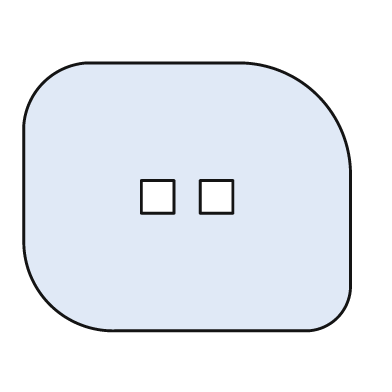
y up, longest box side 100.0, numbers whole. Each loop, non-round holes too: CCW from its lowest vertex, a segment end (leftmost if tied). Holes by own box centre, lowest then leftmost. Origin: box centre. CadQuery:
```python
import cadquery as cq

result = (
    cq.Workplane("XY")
    .moveTo(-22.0, -41.0)
    .lineTo(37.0, -41.0)
    .threePointArc((46.0, -37.0), (50.0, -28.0))
    .lineTo(50.0, 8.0)
    .threePointArc((40.0, 31.0), (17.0, 41.0))
    .lineTo(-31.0, 41.0)
    .threePointArc((-44.0, 35.0), (-50.0, 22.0))
    .lineTo(-50.0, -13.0)
    .threePointArc((-42.0, -33.0), (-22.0, -41.0))
    .close()
    .moveTo(-14.0, -5.0)
    .lineTo(-4.0, -5.0)
    .lineTo(-4.0, 5.0)
    .lineTo(-14.0, 5.0)
    .close()
    .moveTo(4.0, -5.0)
    .lineTo(14.0, -5.0)
    .lineTo(14.0, 5.0)
    .lineTo(4.0, 5.0)
    .close()
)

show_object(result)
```